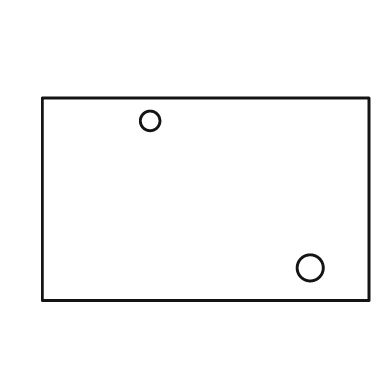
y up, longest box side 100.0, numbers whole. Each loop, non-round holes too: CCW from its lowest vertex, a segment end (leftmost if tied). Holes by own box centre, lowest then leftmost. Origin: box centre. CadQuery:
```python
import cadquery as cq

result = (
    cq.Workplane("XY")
    .moveTo(-50.0, -31.0)
    .lineTo(50.0, -31.0)
    .lineTo(50.0, 31.0)
    .lineTo(-50.0, 31.0)
    .close()
    .moveTo(32.0, -21.0)
    .circle(4.0)
    .moveTo(-17.0, 24.0)
    .circle(3.0)
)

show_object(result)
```